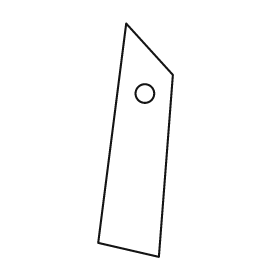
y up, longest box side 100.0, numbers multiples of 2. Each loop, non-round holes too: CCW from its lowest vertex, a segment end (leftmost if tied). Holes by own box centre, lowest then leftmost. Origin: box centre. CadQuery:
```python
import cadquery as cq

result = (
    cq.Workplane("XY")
    .moveTo(10.0, -50.0)
    .lineTo(16.0, 28.0)
    .lineTo(-4.0, 50.0)
    .lineTo(-16.0, -44.0)
    .close()
    .moveTo(4.0, 20.0)
    .circle(4.0)
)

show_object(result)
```